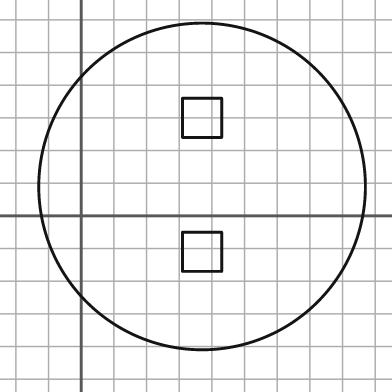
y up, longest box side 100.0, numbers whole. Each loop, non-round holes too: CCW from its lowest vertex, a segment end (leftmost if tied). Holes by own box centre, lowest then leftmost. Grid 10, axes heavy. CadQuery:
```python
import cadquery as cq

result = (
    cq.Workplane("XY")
    .moveTo(37.0, 9.0)
    .circle(50.0)
    .moveTo(31.0, -17.0)
    .lineTo(43.0, -17.0)
    .lineTo(43.0, -5.0)
    .lineTo(31.0, -5.0)
    .close()
    .moveTo(31.0, 24.0)
    .lineTo(43.0, 24.0)
    .lineTo(43.0, 36.0)
    .lineTo(31.0, 36.0)
    .close()
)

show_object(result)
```